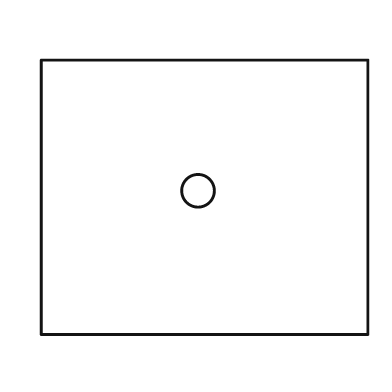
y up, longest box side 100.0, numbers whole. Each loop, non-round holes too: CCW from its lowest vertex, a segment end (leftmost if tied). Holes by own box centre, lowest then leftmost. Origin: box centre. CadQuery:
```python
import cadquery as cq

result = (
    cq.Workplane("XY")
    .moveTo(-50.0, -42.0)
    .lineTo(50.0, -42.0)
    .lineTo(50.0, 42.0)
    .lineTo(-50.0, 42.0)
    .close()
    .moveTo(-2.0, 2.0)
    .circle(5.0)
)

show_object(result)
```